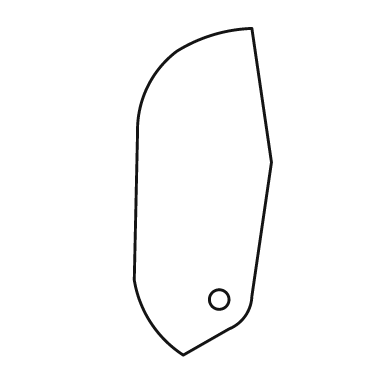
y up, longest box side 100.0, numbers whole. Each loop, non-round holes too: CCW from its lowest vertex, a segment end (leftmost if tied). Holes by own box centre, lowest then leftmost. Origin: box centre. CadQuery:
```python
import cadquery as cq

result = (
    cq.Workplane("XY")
    .moveTo(-6.0, -50.0)
    .lineTo(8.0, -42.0)
    .threePointArc((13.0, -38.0), (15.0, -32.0))
    .lineTo(21.0, 9.0)
    .lineTo(15.0, 50.0)
    .threePointArc((3.0, 48.0), (-8.0, 43.0))
    .threePointArc((-17.0, 32.0), (-20.0, 18.0))
    .lineTo(-21.0, -27.0)
    .threePointArc((-16.0, -40.0), (-6.0, -50.0))
    .close()
    .moveTo(5.0, -33.0)
    .circle(3.0)
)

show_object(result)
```